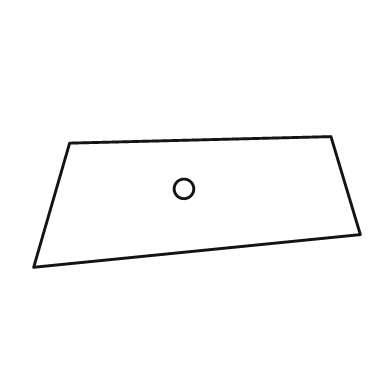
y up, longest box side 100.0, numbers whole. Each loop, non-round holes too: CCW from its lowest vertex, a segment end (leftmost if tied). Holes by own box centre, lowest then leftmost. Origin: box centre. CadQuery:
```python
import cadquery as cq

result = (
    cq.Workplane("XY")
    .moveTo(-50.0, -20.0)
    .lineTo(50.0, -10.0)
    .lineTo(41.0, 20.0)
    .lineTo(-39.0, 18.0)
    .close()
    .moveTo(-4.0, 4.0)
    .circle(3.0)
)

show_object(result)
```